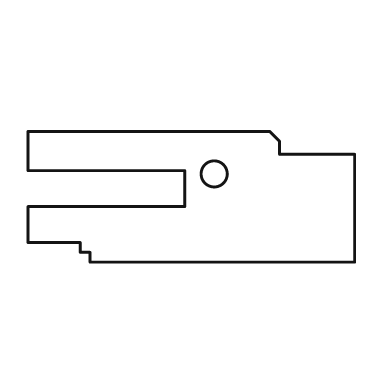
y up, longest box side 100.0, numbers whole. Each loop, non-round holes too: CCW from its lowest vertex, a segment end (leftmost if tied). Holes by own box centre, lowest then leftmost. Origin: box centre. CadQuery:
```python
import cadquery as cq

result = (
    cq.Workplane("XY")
    .moveTo(-31.0, -20.0)
    .lineTo(50.0, -20.0)
    .lineTo(50.0, 13.0)
    .lineTo(27.0, 13.0)
    .lineTo(27.0, 17.0)
    .lineTo(24.0, 20.0)
    .lineTo(-50.0, 20.0)
    .lineTo(-50.0, 8.0)
    .lineTo(-2.0, 8.0)
    .lineTo(-2.0, -3.0)
    .lineTo(-50.0, -3.0)
    .lineTo(-50.0, -14.0)
    .lineTo(-34.0, -14.0)
    .lineTo(-34.0, -17.0)
    .lineTo(-31.0, -17.0)
    .close()
    .moveTo(7.0, 7.0)
    .circle(4.0)
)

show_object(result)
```